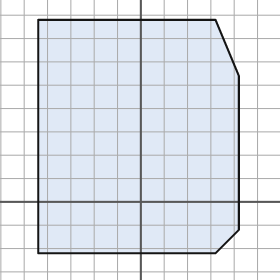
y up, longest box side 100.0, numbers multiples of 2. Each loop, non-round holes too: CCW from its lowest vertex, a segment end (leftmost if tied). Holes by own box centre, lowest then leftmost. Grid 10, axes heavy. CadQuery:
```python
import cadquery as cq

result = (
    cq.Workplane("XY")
    .moveTo(-44.0, -22.0)
    .lineTo(32.0, -22.0)
    .lineTo(42.0, -12.0)
    .lineTo(42.0, 54.0)
    .lineTo(32.0, 78.0)
    .lineTo(-44.0, 78.0)
    .close()
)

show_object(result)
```